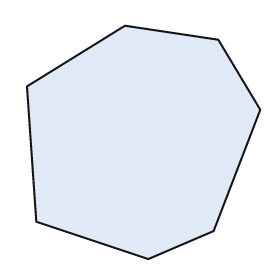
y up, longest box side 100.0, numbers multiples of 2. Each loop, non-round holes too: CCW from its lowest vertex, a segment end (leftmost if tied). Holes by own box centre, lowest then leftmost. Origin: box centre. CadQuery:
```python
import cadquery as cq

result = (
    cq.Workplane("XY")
    .moveTo(2.0, -50.0)
    .lineTo(30.0, -38.0)
    .lineTo(50.0, 14.0)
    .lineTo(32.0, 44.0)
    .lineTo(-8.0, 50.0)
    .lineTo(-50.0, 24.0)
    .lineTo(-46.0, -34.0)
    .close()
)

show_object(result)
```